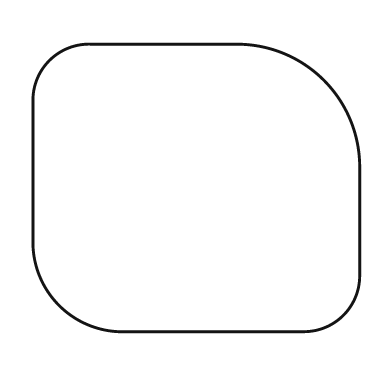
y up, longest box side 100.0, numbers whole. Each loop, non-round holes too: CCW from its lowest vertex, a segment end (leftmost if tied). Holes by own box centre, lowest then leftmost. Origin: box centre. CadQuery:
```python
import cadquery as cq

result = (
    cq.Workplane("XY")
    .moveTo(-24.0, -44.0)
    .lineTo(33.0, -44.0)
    .threePointArc((45.0, -39.0), (50.0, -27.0))
    .lineTo(50.0, 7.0)
    .threePointArc((39.0, 33.0), (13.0, 44.0))
    .lineTo(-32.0, 44.0)
    .threePointArc((-45.0, 39.0), (-50.0, 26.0))
    .lineTo(-50.0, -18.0)
    .threePointArc((-42.0, -36.0), (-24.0, -44.0))
    .close()
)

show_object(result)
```